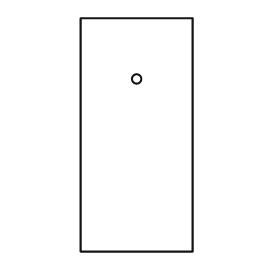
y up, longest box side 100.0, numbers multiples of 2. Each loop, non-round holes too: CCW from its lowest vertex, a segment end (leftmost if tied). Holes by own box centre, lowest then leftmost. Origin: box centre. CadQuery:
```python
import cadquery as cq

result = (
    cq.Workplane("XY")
    .moveTo(-24.0, -50.0)
    .lineTo(24.0, -50.0)
    .lineTo(24.0, 50.0)
    .lineTo(-24.0, 50.0)
    .close()
    .moveTo(0.0, 24.0)
    .circle(2.0)
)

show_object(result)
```